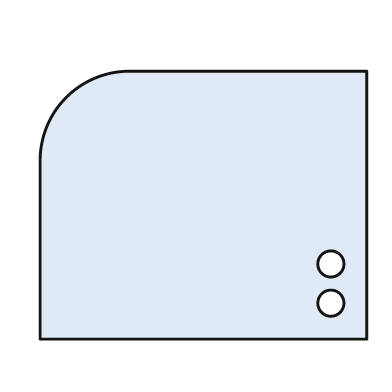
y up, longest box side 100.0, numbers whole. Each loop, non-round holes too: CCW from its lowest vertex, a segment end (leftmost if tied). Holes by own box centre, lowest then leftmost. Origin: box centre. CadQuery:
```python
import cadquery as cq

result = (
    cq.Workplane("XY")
    .moveTo(-50.0, -41.0)
    .lineTo(50.0, -41.0)
    .lineTo(50.0, 41.0)
    .lineTo(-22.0, 41.0)
    .threePointArc((-42.0, 33.0), (-50.0, 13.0))
    .close()
    .moveTo(39.0, -30.0)
    .circle(4.0)
    .moveTo(39.0, -18.0)
    .circle(4.0)
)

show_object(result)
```